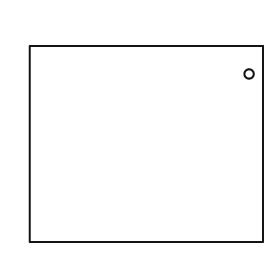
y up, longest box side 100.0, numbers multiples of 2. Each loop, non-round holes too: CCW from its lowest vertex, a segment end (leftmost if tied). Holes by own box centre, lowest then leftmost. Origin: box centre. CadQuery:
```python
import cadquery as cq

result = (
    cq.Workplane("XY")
    .moveTo(-50.0, -42.0)
    .lineTo(50.0, -42.0)
    .lineTo(50.0, 42.0)
    .lineTo(-50.0, 42.0)
    .close()
    .moveTo(44.0, 30.0)
    .circle(2.0)
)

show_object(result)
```